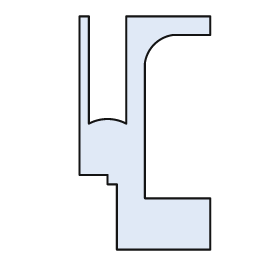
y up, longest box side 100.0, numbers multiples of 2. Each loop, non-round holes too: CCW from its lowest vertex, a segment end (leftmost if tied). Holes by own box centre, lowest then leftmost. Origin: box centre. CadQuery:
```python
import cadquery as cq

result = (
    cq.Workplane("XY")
    .moveTo(-12.0, -50.0)
    .lineTo(28.0, -50.0)
    .lineTo(28.0, -28.0)
    .lineTo(0.0, -28.0)
    .lineTo(0.0, 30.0)
    .threePointArc((4.0, 38.0), (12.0, 42.0))
    .lineTo(28.0, 42.0)
    .lineTo(28.0, 50.0)
    .lineTo(-8.0, 50.0)
    .lineTo(-8.0, 4.0)
    .threePointArc((-16.0, 6.0), (-24.0, 4.0))
    .lineTo(-24.0, 50.0)
    .lineTo(-28.0, 50.0)
    .lineTo(-28.0, -18.0)
    .lineTo(-16.0, -18.0)
    .lineTo(-16.0, -22.0)
    .lineTo(-12.0, -22.0)
    .close()
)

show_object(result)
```